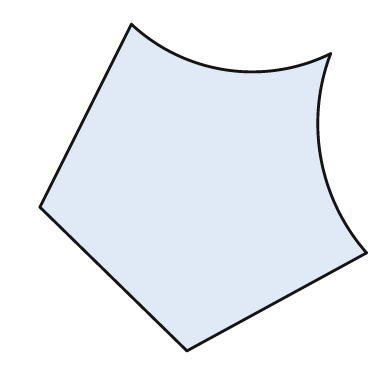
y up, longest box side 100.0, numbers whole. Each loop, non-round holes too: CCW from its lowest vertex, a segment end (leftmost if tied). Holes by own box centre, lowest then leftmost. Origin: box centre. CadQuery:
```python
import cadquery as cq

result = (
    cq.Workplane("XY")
    .moveTo(-5.0, -50.0)
    .lineTo(50.0, -20.0)
    .threePointArc((36.0, 9.0), (39.0, 41.0))
    .threePointArc((7.0, 36.0), (-22.0, 50.0))
    .lineTo(-50.0, -6.0)
    .close()
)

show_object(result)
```